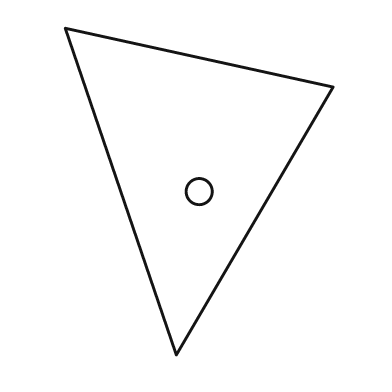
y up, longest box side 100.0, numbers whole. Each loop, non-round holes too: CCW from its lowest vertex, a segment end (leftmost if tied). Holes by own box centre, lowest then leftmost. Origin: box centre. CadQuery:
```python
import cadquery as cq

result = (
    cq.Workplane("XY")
    .moveTo(-7.0, -50.0)
    .lineTo(41.0, 32.0)
    .lineTo(-41.0, 50.0)
    .close()
    .moveTo(0.0, 0.0)
    .circle(4.0)
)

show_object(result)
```